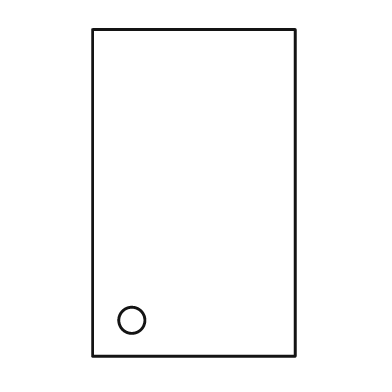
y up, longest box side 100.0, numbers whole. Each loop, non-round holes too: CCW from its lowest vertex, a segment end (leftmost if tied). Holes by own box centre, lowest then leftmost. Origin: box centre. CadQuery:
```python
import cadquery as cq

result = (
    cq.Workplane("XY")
    .moveTo(-31.0, -50.0)
    .lineTo(31.0, -50.0)
    .lineTo(31.0, 50.0)
    .lineTo(-31.0, 50.0)
    .close()
    .moveTo(-19.0, -39.0)
    .circle(4.0)
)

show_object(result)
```